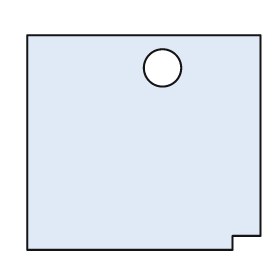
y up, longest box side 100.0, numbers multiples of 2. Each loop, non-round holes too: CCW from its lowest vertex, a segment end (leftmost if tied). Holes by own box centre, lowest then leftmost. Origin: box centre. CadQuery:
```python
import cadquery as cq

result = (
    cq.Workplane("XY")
    .moveTo(-50.0, -46.0)
    .lineTo(38.0, -46.0)
    .lineTo(38.0, -40.0)
    .lineTo(50.0, -40.0)
    .lineTo(50.0, 46.0)
    .lineTo(-50.0, 46.0)
    .close()
    .moveTo(8.0, 32.0)
    .circle(8.0)
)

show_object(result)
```